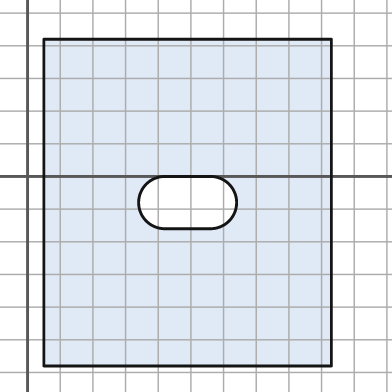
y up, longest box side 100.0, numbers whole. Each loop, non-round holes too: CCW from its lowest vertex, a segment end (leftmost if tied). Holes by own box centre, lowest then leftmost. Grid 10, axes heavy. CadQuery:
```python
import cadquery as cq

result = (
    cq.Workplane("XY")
    .moveTo(5.0, -58.0)
    .lineTo(93.0, -58.0)
    .lineTo(93.0, 42.0)
    .lineTo(5.0, 42.0)
    .close()
    .moveTo(42.0, -16.0)
    .lineTo(56.0, -16.0)
    .threePointArc((64.0, -8.0), (56.0, 0.0))
    .lineTo(42.0, 0.0)
    .threePointArc((34.0, -8.0), (42.0, -16.0))
    .close()
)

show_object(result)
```